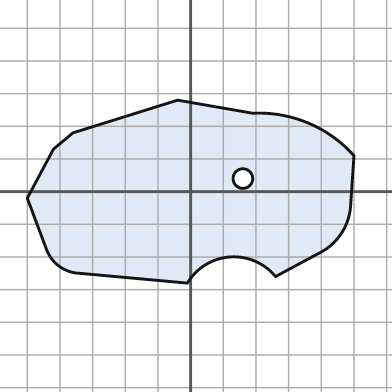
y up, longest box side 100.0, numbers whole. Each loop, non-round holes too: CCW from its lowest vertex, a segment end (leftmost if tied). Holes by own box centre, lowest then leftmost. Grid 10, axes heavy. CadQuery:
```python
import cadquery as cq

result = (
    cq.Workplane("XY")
    .moveTo(-1.0, -28.0)
    .threePointArc((12.0, -20.0), (26.0, -26.0))
    .lineTo(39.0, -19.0)
    .threePointArc((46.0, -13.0), (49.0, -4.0))
    .lineTo(50.0, 11.0)
    .threePointArc((36.0, 21.0), (19.0, 24.0))
    .lineTo(-4.0, 28.0)
    .lineTo(-36.0, 18.0)
    .lineTo(-42.0, 13.0)
    .lineTo(-50.0, -2.0)
    .lineTo(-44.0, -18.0)
    .threePointArc((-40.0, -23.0), (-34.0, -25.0))
    .close()
    .moveTo(16.0, 4.0)
    .circle(3.0)
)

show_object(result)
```